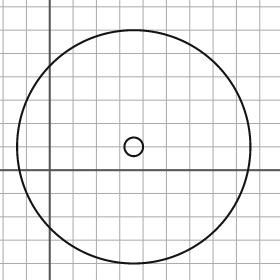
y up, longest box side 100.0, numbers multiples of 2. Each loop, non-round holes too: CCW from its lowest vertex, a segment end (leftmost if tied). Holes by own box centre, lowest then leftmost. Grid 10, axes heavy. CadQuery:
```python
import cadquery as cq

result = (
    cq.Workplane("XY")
    .moveTo(36.0, 10.0)
    .circle(50.0)
    .moveTo(36.0, 10.0)
    .circle(4.0)
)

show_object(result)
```